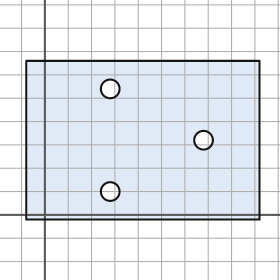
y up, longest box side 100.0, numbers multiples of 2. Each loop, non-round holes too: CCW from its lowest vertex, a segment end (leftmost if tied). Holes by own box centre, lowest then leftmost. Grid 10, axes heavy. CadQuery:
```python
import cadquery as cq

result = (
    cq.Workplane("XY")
    .moveTo(-8.0, -2.0)
    .lineTo(92.0, -2.0)
    .lineTo(92.0, 66.0)
    .lineTo(-8.0, 66.0)
    .close()
    .moveTo(28.0, 10.0)
    .circle(4.0)
    .moveTo(68.0, 32.0)
    .circle(4.0)
    .moveTo(28.0, 54.0)
    .circle(4.0)
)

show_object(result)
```